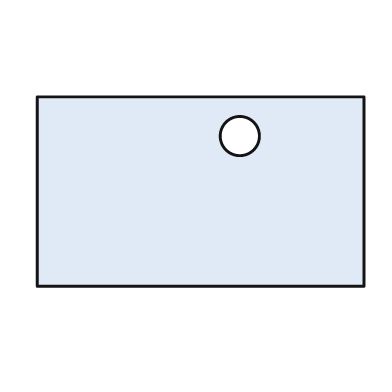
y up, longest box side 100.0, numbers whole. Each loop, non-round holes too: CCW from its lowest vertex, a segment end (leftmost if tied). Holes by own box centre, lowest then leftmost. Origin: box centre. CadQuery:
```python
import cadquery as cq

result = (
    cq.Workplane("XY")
    .moveTo(-50.0, -29.0)
    .lineTo(50.0, -29.0)
    .lineTo(50.0, 29.0)
    .lineTo(-50.0, 29.0)
    .close()
    .moveTo(12.0, 17.0)
    .circle(6.0)
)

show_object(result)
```